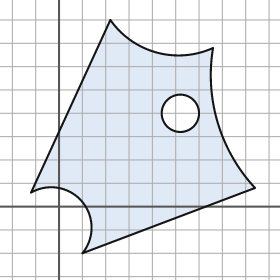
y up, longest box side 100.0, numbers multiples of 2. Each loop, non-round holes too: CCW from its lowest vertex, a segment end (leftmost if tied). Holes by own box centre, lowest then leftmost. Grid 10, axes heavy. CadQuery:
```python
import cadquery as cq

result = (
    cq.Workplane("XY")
    .moveTo(10.0, -20.0)
    .lineTo(84.0, 8.0)
    .threePointArc((68.0, 36.0), (66.0, 68.0))
    .threePointArc((42.0, 66.0), (22.0, 80.0))
    .lineTo(-12.0, 6.0)
    .threePointArc((10.0, 2.0), (10.0, -20.0))
    .close()
    .moveTo(52.0, 40.0)
    .circle(8.0)
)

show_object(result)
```